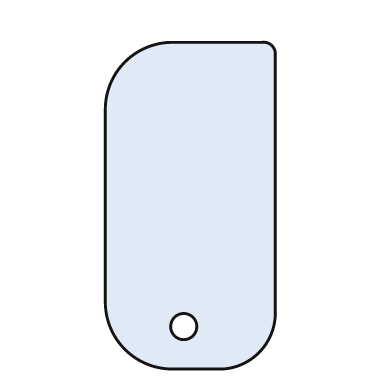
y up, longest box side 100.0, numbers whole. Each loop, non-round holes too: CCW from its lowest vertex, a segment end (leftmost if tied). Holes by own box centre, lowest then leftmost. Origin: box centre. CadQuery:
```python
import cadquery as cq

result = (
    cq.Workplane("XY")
    .moveTo(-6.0, -50.0)
    .lineTo(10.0, -50.0)
    .threePointArc((21.0, -45.0), (26.0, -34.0))
    .lineTo(26.0, 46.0)
    .threePointArc((25.0, 49.0), (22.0, 50.0))
    .lineTo(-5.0, 50.0)
    .threePointArc((-20.0, 44.0), (-26.0, 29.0))
    .lineTo(-26.0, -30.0)
    .threePointArc((-20.0, -44.0), (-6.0, -50.0))
    .close()
    .moveTo(-2.0, -37.0)
    .circle(4.0)
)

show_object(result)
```